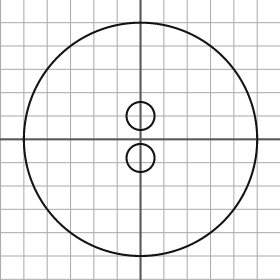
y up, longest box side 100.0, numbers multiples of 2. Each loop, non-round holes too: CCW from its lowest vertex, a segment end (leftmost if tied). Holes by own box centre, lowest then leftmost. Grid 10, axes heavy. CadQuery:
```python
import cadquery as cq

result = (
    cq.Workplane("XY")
    .moveTo(0.0, 0.0)
    .circle(50.0)
    .moveTo(0.0, -8.0)
    .circle(6.0)
    .moveTo(0.0, 10.0)
    .circle(6.0)
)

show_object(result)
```